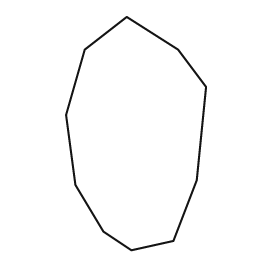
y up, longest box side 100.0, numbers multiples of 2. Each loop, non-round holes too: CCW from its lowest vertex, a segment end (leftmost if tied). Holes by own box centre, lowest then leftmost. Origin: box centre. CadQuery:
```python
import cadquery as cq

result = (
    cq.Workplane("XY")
    .moveTo(-2.0, -50.0)
    .lineTo(16.0, -46.0)
    .lineTo(26.0, -20.0)
    .lineTo(30.0, 20.0)
    .lineTo(18.0, 36.0)
    .lineTo(-4.0, 50.0)
    .lineTo(-22.0, 36.0)
    .lineTo(-30.0, 8.0)
    .lineTo(-26.0, -22.0)
    .lineTo(-14.0, -42.0)
    .close()
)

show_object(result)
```